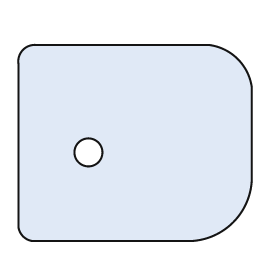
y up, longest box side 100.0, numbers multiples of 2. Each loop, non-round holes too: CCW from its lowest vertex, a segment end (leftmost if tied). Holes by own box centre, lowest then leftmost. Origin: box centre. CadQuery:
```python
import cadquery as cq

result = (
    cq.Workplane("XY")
    .moveTo(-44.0, -42.0)
    .lineTo(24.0, -42.0)
    .threePointArc((42.0, -34.0), (50.0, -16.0))
    .lineTo(50.0, 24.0)
    .threePointArc((44.0, 36.0), (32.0, 42.0))
    .lineTo(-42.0, 42.0)
    .threePointArc((-48.0, 40.0), (-50.0, 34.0))
    .lineTo(-50.0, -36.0)
    .threePointArc((-48.0, -40.0), (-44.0, -42.0))
    .close()
    .moveTo(-20.0, -4.0)
    .circle(6.0)
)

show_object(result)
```